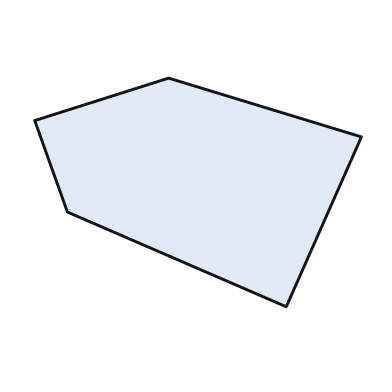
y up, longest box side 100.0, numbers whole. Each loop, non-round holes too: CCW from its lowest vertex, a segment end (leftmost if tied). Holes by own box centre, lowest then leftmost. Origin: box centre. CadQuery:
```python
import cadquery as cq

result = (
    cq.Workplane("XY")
    .moveTo(27.0, -35.0)
    .lineTo(50.0, 17.0)
    .lineTo(-9.0, 35.0)
    .lineTo(-50.0, 22.0)
    .lineTo(-40.0, -6.0)
    .close()
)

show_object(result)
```